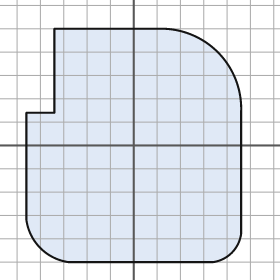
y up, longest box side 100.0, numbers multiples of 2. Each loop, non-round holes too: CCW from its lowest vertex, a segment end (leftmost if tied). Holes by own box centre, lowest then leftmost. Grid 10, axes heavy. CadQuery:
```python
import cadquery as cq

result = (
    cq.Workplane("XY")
    .moveTo(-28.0, -50.0)
    .lineTo(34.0, -50.0)
    .threePointArc((42.0, -46.0), (46.0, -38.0))
    .lineTo(46.0, 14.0)
    .threePointArc((36.0, 40.0), (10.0, 50.0))
    .lineTo(-34.0, 50.0)
    .lineTo(-34.0, 14.0)
    .lineTo(-46.0, 14.0)
    .lineTo(-46.0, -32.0)
    .threePointArc((-40.0, -44.0), (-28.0, -50.0))
    .close()
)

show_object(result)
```